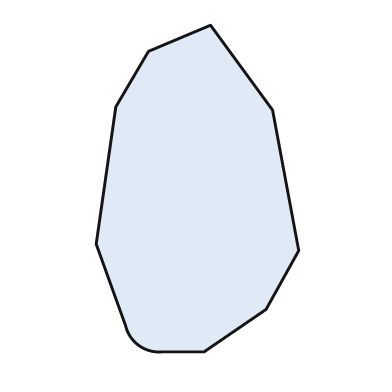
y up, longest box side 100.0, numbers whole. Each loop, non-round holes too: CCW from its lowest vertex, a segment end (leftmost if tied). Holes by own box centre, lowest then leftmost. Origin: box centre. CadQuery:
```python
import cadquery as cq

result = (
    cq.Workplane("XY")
    .moveTo(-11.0, -50.0)
    .lineTo(2.0, -50.0)
    .lineTo(21.0, -37.0)
    .lineTo(31.0, -19.0)
    .lineTo(23.0, 24.0)
    .lineTo(4.0, 50.0)
    .lineTo(-15.0, 42.0)
    .lineTo(-25.0, 25.0)
    .lineTo(-31.0, -17.0)
    .lineTo(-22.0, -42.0)
    .threePointArc((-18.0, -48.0), (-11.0, -50.0))
    .close()
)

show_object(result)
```